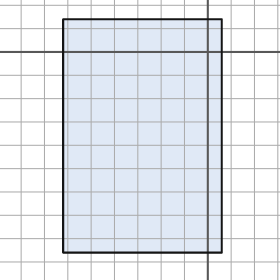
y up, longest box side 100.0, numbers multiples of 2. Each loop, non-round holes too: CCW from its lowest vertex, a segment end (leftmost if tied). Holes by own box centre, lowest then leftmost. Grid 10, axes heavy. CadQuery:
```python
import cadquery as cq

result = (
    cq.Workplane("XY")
    .moveTo(-62.0, -86.0)
    .lineTo(6.0, -86.0)
    .lineTo(6.0, 14.0)
    .lineTo(-62.0, 14.0)
    .close()
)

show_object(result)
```